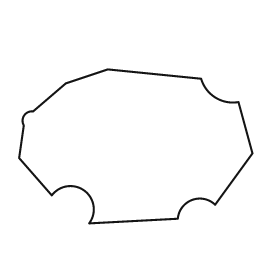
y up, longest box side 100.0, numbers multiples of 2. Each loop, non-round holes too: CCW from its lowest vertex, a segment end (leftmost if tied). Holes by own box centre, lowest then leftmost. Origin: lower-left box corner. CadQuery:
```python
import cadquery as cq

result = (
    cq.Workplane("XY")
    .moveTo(30.0, 0.0)
    .lineTo(68.0, 2.0)
    .threePointArc((74.0, 10.0), (84.0, 8.0))
    .lineTo(100.0, 30.0)
    .lineTo(94.0, 52.0)
    .threePointArc((84.0, 54.0), (78.0, 62.0))
    .lineTo(38.0, 66.0)
    .lineTo(20.0, 60.0)
    .lineTo(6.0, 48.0)
    .threePointArc((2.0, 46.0), (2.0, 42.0))
    .lineTo(0.0, 28.0)
    .lineTo(14.0, 12.0)
    .threePointArc((28.0, 14.0), (30.0, 0.0))
    .close()
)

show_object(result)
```